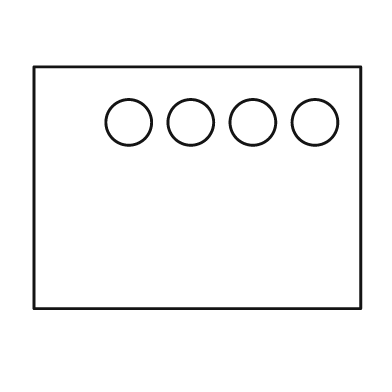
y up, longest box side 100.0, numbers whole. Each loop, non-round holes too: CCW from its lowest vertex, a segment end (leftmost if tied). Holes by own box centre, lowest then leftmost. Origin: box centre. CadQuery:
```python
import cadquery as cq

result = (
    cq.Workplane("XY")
    .moveTo(-50.0, -37.0)
    .lineTo(50.0, -37.0)
    .lineTo(50.0, 37.0)
    .lineTo(-50.0, 37.0)
    .close()
    .moveTo(-21.0, 20.0)
    .circle(7.0)
    .moveTo(-2.0, 20.0)
    .circle(7.0)
    .moveTo(17.0, 20.0)
    .circle(7.0)
    .moveTo(36.0, 20.0)
    .circle(7.0)
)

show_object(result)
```